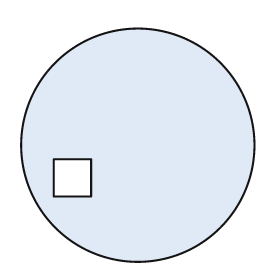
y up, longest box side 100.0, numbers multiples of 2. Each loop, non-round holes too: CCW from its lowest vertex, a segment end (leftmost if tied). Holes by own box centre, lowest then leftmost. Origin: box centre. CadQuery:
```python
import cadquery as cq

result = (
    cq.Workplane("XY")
    .moveTo(0.0, 0.0)
    .circle(50.0)
    .moveTo(-36.0, -22.0)
    .lineTo(-20.0, -22.0)
    .lineTo(-20.0, -6.0)
    .lineTo(-36.0, -6.0)
    .close()
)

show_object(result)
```